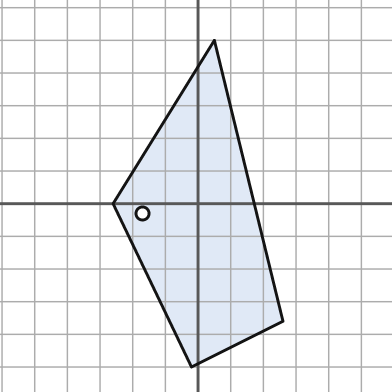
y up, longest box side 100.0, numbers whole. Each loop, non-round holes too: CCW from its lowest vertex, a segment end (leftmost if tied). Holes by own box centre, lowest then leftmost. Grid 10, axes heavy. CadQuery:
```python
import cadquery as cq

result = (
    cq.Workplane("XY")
    .moveTo(-2.0, -50.0)
    .lineTo(26.0, -36.0)
    .lineTo(5.0, 50.0)
    .lineTo(-26.0, 0.0)
    .close()
    .moveTo(-17.0, -3.0)
    .circle(2.0)
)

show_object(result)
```